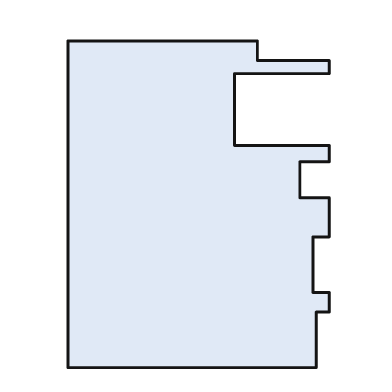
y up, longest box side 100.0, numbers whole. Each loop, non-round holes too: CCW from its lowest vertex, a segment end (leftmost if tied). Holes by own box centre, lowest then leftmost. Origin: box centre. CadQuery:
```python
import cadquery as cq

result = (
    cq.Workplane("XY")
    .moveTo(-40.0, -50.0)
    .lineTo(36.0, -50.0)
    .lineTo(36.0, -33.0)
    .lineTo(40.0, -33.0)
    .lineTo(40.0, -27.0)
    .lineTo(35.0, -27.0)
    .lineTo(35.0, -10.0)
    .lineTo(40.0, -10.0)
    .lineTo(40.0, 2.0)
    .lineTo(31.0, 2.0)
    .lineTo(31.0, 13.0)
    .lineTo(40.0, 13.0)
    .lineTo(40.0, 18.0)
    .lineTo(11.0, 18.0)
    .lineTo(11.0, 40.0)
    .lineTo(40.0, 40.0)
    .lineTo(40.0, 44.0)
    .lineTo(18.0, 44.0)
    .lineTo(18.0, 50.0)
    .lineTo(-40.0, 50.0)
    .close()
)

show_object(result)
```